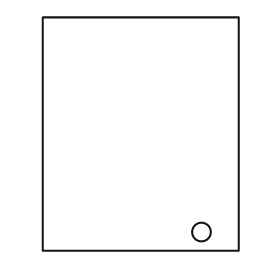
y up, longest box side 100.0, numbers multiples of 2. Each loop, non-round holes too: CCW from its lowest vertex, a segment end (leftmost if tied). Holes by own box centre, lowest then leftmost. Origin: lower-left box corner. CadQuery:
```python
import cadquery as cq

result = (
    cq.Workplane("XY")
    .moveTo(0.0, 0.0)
    .lineTo(84.0, 0.0)
    .lineTo(84.0, 100.0)
    .lineTo(0.0, 100.0)
    .close()
    .moveTo(68.0, 8.0)
    .circle(4.0)
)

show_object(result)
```